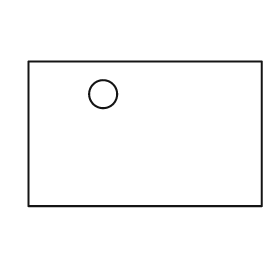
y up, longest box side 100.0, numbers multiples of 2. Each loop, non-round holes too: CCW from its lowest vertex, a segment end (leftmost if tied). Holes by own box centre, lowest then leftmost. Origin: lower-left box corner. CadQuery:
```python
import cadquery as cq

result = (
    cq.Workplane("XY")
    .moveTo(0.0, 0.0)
    .lineTo(100.0, 0.0)
    .lineTo(100.0, 62.0)
    .lineTo(0.0, 62.0)
    .close()
    .moveTo(32.0, 48.0)
    .circle(6.0)
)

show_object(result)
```